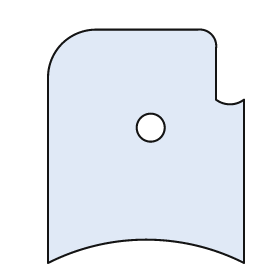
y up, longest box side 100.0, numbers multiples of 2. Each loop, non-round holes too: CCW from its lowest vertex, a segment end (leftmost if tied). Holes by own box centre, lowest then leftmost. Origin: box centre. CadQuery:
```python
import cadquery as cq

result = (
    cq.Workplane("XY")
    .moveTo(-42.0, -50.0)
    .threePointArc((0.0, -40.0), (42.0, -50.0))
    .lineTo(42.0, 20.0)
    .threePointArc((36.0, 18.0), (30.0, 20.0))
    .lineTo(30.0, 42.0)
    .threePointArc((28.0, 48.0), (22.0, 50.0))
    .lineTo(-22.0, 50.0)
    .threePointArc((-36.0, 44.0), (-42.0, 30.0))
    .close()
    .moveTo(2.0, 8.0)
    .circle(6.0)
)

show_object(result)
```